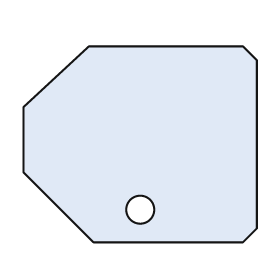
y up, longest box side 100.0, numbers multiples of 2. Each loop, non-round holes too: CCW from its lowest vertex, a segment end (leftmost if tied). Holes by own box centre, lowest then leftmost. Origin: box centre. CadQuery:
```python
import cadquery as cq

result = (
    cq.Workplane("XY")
    .moveTo(-20.0, -42.0)
    .lineTo(44.0, -42.0)
    .lineTo(50.0, -36.0)
    .lineTo(50.0, 36.0)
    .lineTo(44.0, 42.0)
    .lineTo(-22.0, 42.0)
    .lineTo(-50.0, 16.0)
    .lineTo(-50.0, -12.0)
    .close()
    .moveTo(0.0, -28.0)
    .circle(6.0)
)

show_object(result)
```